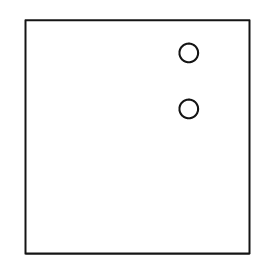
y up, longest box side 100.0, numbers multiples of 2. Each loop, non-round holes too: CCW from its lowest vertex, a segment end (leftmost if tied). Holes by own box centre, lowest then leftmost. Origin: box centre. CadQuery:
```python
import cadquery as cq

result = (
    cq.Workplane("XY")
    .moveTo(-48.0, -50.0)
    .lineTo(48.0, -50.0)
    .lineTo(48.0, 50.0)
    .lineTo(-48.0, 50.0)
    .close()
    .moveTo(22.0, 12.0)
    .circle(4.0)
    .moveTo(22.0, 36.0)
    .circle(4.0)
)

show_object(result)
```